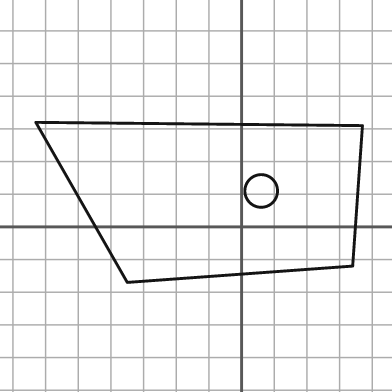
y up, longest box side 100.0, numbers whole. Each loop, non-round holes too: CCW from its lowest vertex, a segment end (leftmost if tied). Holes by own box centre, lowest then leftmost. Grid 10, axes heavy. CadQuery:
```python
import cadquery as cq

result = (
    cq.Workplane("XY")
    .moveTo(-35.0, -17.0)
    .lineTo(34.0, -12.0)
    .lineTo(37.0, 31.0)
    .lineTo(-63.0, 32.0)
    .close()
    .moveTo(6.0, 11.0)
    .circle(5.0)
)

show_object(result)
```